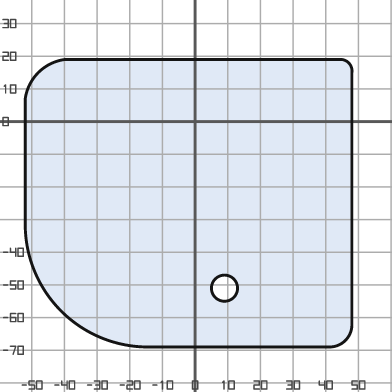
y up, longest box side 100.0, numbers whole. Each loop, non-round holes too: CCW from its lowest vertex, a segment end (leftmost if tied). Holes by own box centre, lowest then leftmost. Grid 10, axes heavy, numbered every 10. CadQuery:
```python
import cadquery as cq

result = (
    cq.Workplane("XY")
    .moveTo(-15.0, -69.0)
    .lineTo(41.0, -69.0)
    .threePointArc((46.0, -67.0), (48.0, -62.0))
    .lineTo(48.0, 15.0)
    .threePointArc((47.0, 18.0), (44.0, 19.0))
    .lineTo(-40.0, 19.0)
    .threePointArc((-48.0, 15.0), (-52.0, 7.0))
    .lineTo(-52.0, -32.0)
    .threePointArc((-41.0, -58.0), (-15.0, -69.0))
    .close()
    .moveTo(9.0, -51.0)
    .circle(4.0)
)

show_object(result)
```